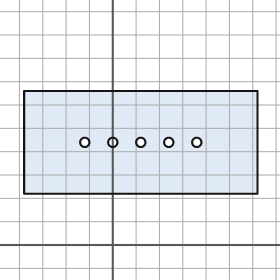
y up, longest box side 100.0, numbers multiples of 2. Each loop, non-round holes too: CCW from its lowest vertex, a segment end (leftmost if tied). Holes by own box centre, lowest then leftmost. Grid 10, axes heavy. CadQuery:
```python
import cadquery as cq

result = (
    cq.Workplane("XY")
    .moveTo(-38.0, 22.0)
    .lineTo(62.0, 22.0)
    .lineTo(62.0, 66.0)
    .lineTo(-38.0, 66.0)
    .close()
    .moveTo(-12.0, 44.0)
    .circle(2.0)
    .moveTo(0.0, 44.0)
    .circle(2.0)
    .moveTo(12.0, 44.0)
    .circle(2.0)
    .moveTo(24.0, 44.0)
    .circle(2.0)
    .moveTo(36.0, 44.0)
    .circle(2.0)
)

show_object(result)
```